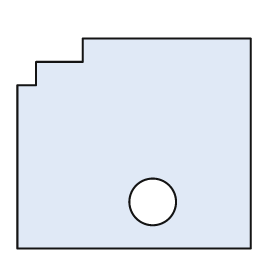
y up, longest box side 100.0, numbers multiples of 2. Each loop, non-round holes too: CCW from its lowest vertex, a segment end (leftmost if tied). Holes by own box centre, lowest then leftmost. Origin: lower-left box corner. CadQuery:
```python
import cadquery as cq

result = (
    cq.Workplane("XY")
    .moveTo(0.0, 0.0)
    .lineTo(100.0, 0.0)
    .lineTo(100.0, 90.0)
    .lineTo(28.0, 90.0)
    .lineTo(28.0, 80.0)
    .lineTo(8.0, 80.0)
    .lineTo(8.0, 70.0)
    .lineTo(0.0, 70.0)
    .close()
    .moveTo(58.0, 20.0)
    .circle(10.0)
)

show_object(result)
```